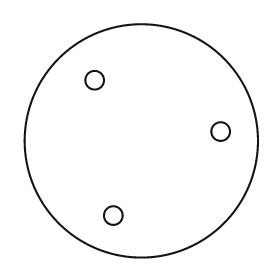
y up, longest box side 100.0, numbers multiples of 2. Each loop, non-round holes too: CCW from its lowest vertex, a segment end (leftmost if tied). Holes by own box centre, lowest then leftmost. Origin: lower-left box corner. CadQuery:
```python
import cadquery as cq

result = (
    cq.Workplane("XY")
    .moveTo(50.0, 50.0)
    .circle(50.0)
    .moveTo(38.0, 18.0)
    .circle(4.0)
    .moveTo(84.0, 54.0)
    .circle(4.0)
    .moveTo(30.0, 76.0)
    .circle(4.0)
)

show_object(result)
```